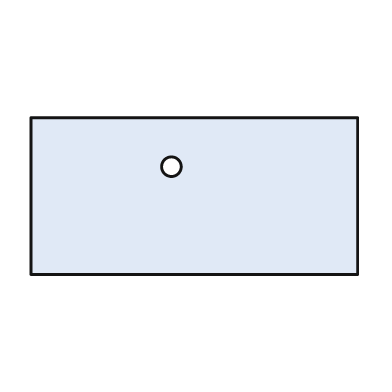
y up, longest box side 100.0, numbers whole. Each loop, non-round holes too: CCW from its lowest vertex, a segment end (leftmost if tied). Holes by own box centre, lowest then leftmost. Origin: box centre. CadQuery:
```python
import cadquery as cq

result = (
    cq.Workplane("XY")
    .moveTo(-50.0, -24.0)
    .lineTo(50.0, -24.0)
    .lineTo(50.0, 24.0)
    .lineTo(-50.0, 24.0)
    .close()
    .moveTo(-7.0, 9.0)
    .circle(3.0)
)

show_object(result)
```